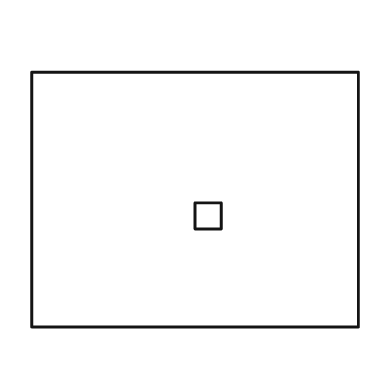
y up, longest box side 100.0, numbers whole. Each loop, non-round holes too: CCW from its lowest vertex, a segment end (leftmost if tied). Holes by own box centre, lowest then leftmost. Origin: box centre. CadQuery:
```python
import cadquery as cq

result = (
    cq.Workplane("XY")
    .moveTo(-50.0, -39.0)
    .lineTo(50.0, -39.0)
    .lineTo(50.0, 39.0)
    .lineTo(-50.0, 39.0)
    .close()
    .moveTo(0.0, -9.0)
    .lineTo(8.0, -9.0)
    .lineTo(8.0, -1.0)
    .lineTo(0.0, -1.0)
    .close()
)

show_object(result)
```